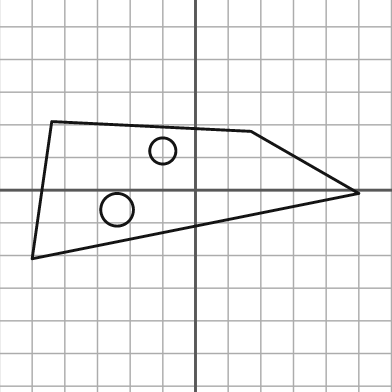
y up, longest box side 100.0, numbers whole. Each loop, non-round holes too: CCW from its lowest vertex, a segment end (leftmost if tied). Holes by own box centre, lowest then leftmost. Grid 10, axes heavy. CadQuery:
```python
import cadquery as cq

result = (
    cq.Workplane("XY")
    .moveTo(-50.0, -21.0)
    .lineTo(50.0, -1.0)
    .lineTo(17.0, 18.0)
    .lineTo(-44.0, 21.0)
    .close()
    .moveTo(-24.0, -6.0)
    .circle(5.0)
    .moveTo(-10.0, 12.0)
    .circle(4.0)
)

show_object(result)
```